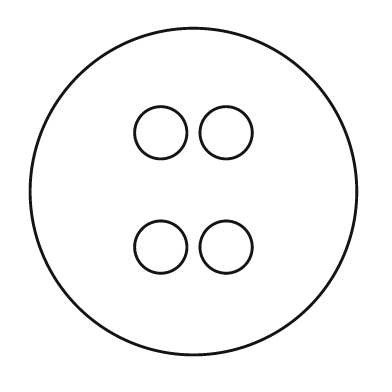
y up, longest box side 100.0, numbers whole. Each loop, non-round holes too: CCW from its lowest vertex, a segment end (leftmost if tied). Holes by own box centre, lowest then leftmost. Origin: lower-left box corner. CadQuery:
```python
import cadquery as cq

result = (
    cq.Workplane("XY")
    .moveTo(50.0, 50.0)
    .circle(50.0)
    .moveTo(40.0, 33.0)
    .circle(8.0)
    .moveTo(60.0, 33.0)
    .circle(8.0)
    .moveTo(40.0, 68.0)
    .circle(8.0)
    .moveTo(60.0, 68.0)
    .circle(8.0)
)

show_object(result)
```